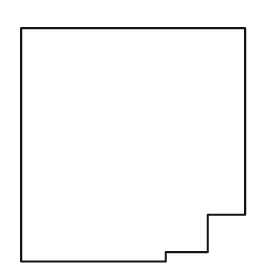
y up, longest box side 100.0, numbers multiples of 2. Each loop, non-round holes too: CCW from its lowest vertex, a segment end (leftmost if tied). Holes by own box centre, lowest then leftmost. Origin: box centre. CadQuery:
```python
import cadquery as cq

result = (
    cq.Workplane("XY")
    .moveTo(-48.0, -50.0)
    .lineTo(14.0, -50.0)
    .lineTo(14.0, -46.0)
    .lineTo(32.0, -46.0)
    .lineTo(32.0, -30.0)
    .lineTo(48.0, -30.0)
    .lineTo(48.0, 50.0)
    .lineTo(-48.0, 50.0)
    .close()
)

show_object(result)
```